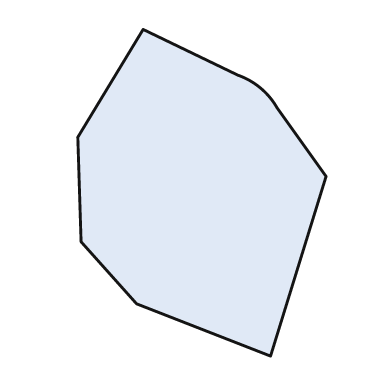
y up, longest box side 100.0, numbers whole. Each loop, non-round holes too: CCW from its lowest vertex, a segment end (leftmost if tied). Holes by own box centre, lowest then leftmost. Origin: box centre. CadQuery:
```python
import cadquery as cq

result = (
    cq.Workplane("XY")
    .moveTo(21.0, -50.0)
    .lineTo(38.0, 5.0)
    .lineTo(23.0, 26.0)
    .threePointArc((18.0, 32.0), (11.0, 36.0))
    .lineTo(-18.0, 50.0)
    .lineTo(-38.0, 17.0)
    .lineTo(-37.0, -15.0)
    .lineTo(-20.0, -34.0)
    .close()
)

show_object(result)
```